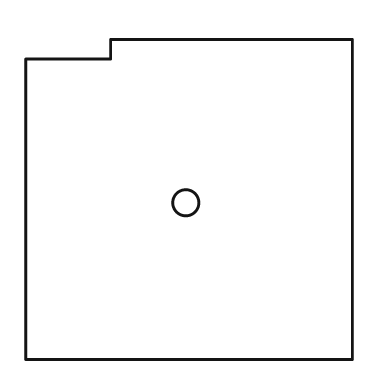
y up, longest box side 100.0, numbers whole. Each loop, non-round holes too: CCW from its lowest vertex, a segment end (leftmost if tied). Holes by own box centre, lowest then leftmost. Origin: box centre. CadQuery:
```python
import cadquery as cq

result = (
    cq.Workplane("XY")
    .moveTo(-50.0, -49.0)
    .lineTo(50.0, -49.0)
    .lineTo(50.0, 49.0)
    .lineTo(-24.0, 49.0)
    .lineTo(-24.0, 43.0)
    .lineTo(-50.0, 43.0)
    .close()
    .moveTo(-1.0, -1.0)
    .circle(4.0)
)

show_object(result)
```